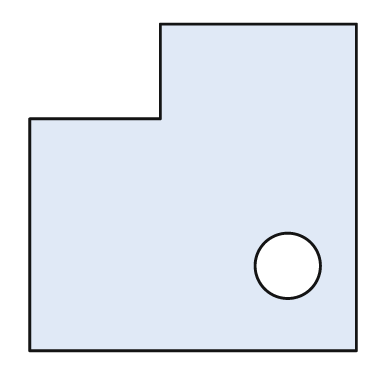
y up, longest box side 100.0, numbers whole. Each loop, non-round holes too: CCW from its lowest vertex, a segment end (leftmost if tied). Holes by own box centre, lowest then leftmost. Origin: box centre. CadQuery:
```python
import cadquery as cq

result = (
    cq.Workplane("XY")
    .moveTo(-50.0, -50.0)
    .lineTo(50.0, -50.0)
    .lineTo(50.0, 50.0)
    .lineTo(-10.0, 50.0)
    .lineTo(-10.0, 21.0)
    .lineTo(-50.0, 21.0)
    .close()
    .moveTo(29.0, -24.0)
    .circle(10.0)
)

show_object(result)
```